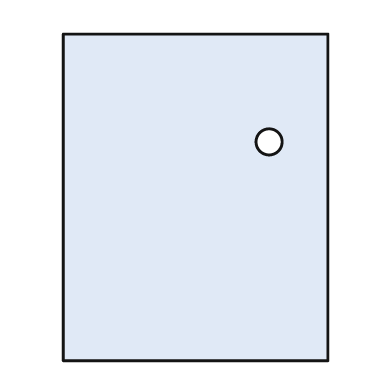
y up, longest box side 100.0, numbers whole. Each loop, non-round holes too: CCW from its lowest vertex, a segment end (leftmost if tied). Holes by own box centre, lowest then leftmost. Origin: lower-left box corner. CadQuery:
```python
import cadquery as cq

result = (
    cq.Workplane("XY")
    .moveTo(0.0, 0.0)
    .lineTo(81.0, 0.0)
    .lineTo(81.0, 100.0)
    .lineTo(0.0, 100.0)
    .close()
    .moveTo(63.0, 67.0)
    .circle(4.0)
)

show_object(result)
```